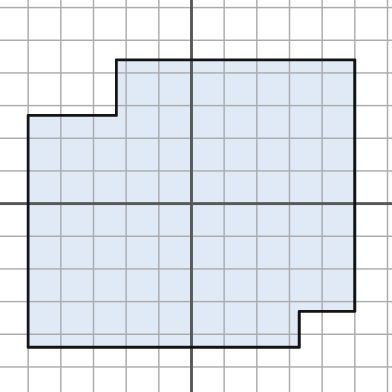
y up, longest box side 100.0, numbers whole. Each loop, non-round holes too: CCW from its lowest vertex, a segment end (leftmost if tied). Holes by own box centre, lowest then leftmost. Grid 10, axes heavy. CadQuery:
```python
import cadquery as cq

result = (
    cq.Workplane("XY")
    .moveTo(-50.0, -44.0)
    .lineTo(33.0, -44.0)
    .lineTo(33.0, -33.0)
    .lineTo(50.0, -33.0)
    .lineTo(50.0, 44.0)
    .lineTo(-23.0, 44.0)
    .lineTo(-23.0, 27.0)
    .lineTo(-50.0, 27.0)
    .close()
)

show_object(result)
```